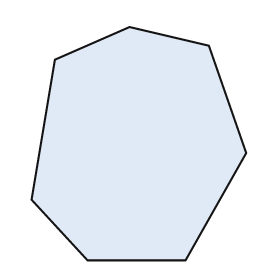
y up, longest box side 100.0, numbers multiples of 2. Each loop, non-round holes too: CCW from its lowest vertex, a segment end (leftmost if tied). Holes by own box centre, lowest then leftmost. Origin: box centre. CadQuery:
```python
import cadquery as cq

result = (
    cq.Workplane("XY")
    .moveTo(-22.0, -50.0)
    .lineTo(20.0, -50.0)
    .lineTo(46.0, -4.0)
    .lineTo(30.0, 42.0)
    .lineTo(-4.0, 50.0)
    .lineTo(-36.0, 36.0)
    .lineTo(-46.0, -24.0)
    .close()
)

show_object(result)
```